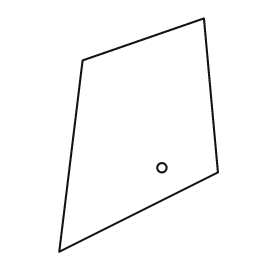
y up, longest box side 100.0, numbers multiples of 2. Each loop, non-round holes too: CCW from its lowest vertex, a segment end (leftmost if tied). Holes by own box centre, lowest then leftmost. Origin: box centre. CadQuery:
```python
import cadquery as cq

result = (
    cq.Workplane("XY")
    .moveTo(-34.0, -50.0)
    .lineTo(34.0, -16.0)
    .lineTo(28.0, 50.0)
    .lineTo(-24.0, 32.0)
    .close()
    .moveTo(10.0, -14.0)
    .circle(2.0)
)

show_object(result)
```